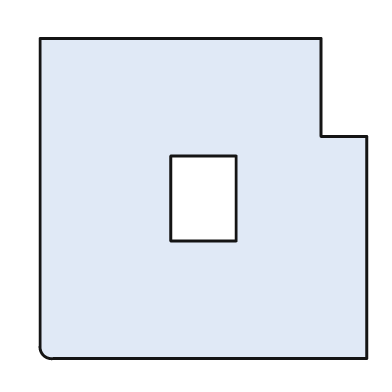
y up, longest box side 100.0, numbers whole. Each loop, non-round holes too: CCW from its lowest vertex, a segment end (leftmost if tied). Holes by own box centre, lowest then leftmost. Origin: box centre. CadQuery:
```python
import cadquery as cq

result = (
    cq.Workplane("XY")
    .moveTo(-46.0, -49.0)
    .lineTo(50.0, -49.0)
    .lineTo(50.0, 19.0)
    .lineTo(36.0, 19.0)
    .lineTo(36.0, 49.0)
    .lineTo(-50.0, 49.0)
    .lineTo(-50.0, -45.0)
    .threePointArc((-49.0, -48.0), (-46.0, -49.0))
    .close()
    .moveTo(-10.0, -13.0)
    .lineTo(10.0, -13.0)
    .lineTo(10.0, 13.0)
    .lineTo(-10.0, 13.0)
    .close()
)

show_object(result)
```